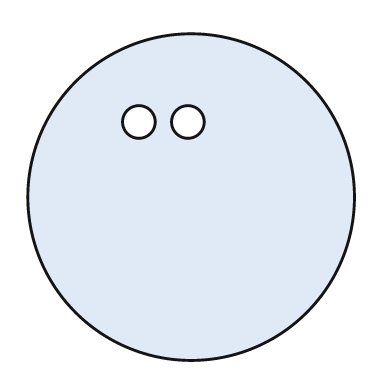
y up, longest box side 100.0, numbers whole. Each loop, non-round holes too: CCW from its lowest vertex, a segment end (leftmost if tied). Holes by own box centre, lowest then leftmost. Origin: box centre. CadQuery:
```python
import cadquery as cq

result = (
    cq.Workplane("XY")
    .moveTo(0.0, 0.0)
    .circle(50.0)
    .moveTo(-16.0, 23.0)
    .circle(5.0)
    .moveTo(-1.0, 23.0)
    .circle(5.0)
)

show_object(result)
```